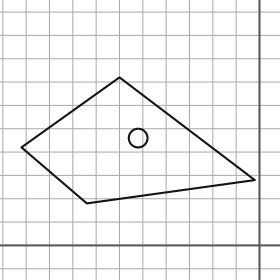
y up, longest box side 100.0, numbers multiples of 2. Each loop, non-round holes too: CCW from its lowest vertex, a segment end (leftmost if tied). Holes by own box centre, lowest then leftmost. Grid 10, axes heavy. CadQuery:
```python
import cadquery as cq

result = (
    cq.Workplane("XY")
    .moveTo(-74.0, 18.0)
    .lineTo(-2.0, 28.0)
    .lineTo(-60.0, 72.0)
    .lineTo(-102.0, 42.0)
    .close()
    .moveTo(-52.0, 46.0)
    .circle(4.0)
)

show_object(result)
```